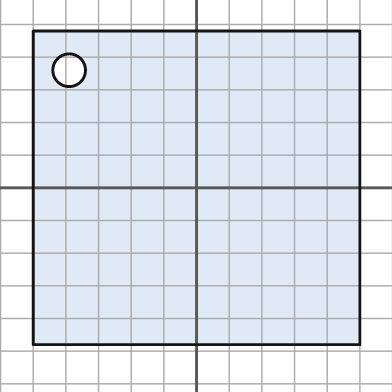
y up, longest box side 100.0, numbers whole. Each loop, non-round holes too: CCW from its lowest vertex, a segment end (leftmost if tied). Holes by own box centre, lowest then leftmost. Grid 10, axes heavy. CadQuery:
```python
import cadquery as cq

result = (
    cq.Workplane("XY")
    .moveTo(-50.0, -48.0)
    .lineTo(50.0, -48.0)
    .lineTo(50.0, 48.0)
    .lineTo(-50.0, 48.0)
    .close()
    .moveTo(-39.0, 36.0)
    .circle(5.0)
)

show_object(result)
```